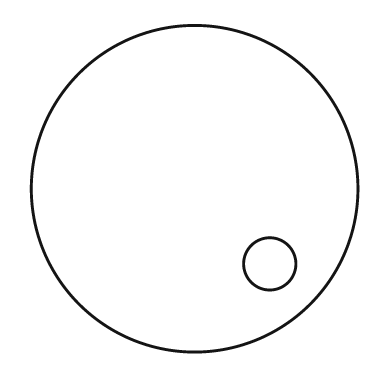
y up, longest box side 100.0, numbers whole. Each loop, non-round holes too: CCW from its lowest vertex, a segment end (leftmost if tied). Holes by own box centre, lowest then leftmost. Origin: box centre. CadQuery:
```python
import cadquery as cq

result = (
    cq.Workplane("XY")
    .moveTo(0.0, 0.0)
    .circle(50.0)
    .moveTo(23.0, -23.0)
    .circle(8.0)
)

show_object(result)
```